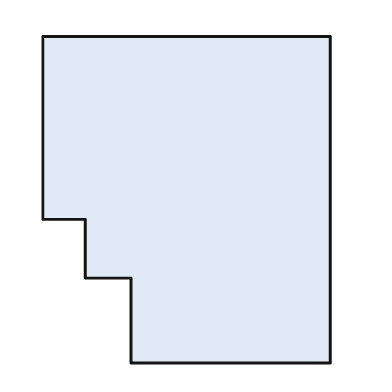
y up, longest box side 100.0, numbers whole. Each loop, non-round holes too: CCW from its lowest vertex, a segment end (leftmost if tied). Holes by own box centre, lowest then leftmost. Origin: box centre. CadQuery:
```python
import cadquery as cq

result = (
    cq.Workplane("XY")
    .moveTo(-17.0, -50.0)
    .lineTo(44.0, -50.0)
    .lineTo(44.0, 50.0)
    .lineTo(-44.0, 50.0)
    .lineTo(-44.0, -6.0)
    .lineTo(-31.0, -6.0)
    .lineTo(-31.0, -24.0)
    .lineTo(-17.0, -24.0)
    .close()
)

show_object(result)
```